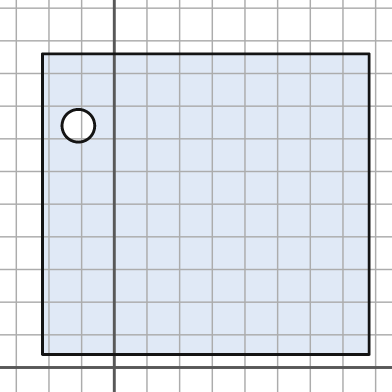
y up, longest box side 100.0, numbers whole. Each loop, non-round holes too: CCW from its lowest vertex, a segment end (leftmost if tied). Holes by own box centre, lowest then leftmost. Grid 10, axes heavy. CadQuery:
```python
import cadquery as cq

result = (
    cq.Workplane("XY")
    .moveTo(-22.0, 4.0)
    .lineTo(78.0, 4.0)
    .lineTo(78.0, 96.0)
    .lineTo(-22.0, 96.0)
    .close()
    .moveTo(-11.0, 74.0)
    .circle(5.0)
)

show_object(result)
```